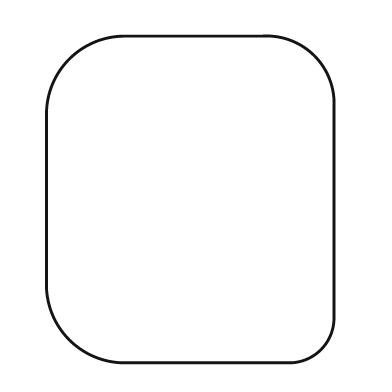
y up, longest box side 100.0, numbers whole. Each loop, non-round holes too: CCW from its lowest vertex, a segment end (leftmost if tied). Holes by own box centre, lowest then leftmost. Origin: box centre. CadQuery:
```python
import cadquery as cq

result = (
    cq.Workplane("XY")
    .moveTo(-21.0, -50.0)
    .lineTo(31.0, -50.0)
    .threePointArc((40.0, -46.0), (44.0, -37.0))
    .lineTo(44.0, 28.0)
    .threePointArc((38.0, 44.0), (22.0, 50.0))
    .lineTo(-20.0, 50.0)
    .threePointArc((-37.0, 43.0), (-44.0, 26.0))
    .lineTo(-44.0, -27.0)
    .threePointArc((-37.0, -43.0), (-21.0, -50.0))
    .close()
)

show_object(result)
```